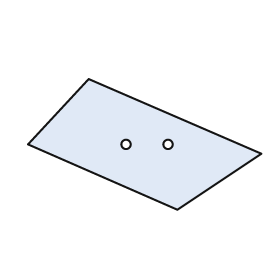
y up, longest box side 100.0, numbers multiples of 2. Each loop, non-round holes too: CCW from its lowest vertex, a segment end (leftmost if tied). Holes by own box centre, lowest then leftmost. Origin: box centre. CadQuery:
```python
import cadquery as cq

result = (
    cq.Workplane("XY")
    .moveTo(14.0, -28.0)
    .lineTo(50.0, -4.0)
    .lineTo(-24.0, 28.0)
    .lineTo(-50.0, 0.0)
    .close()
    .moveTo(-8.0, 0.0)
    .circle(2.0)
    .moveTo(10.0, 0.0)
    .circle(2.0)
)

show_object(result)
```